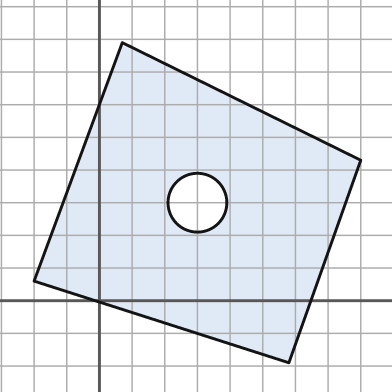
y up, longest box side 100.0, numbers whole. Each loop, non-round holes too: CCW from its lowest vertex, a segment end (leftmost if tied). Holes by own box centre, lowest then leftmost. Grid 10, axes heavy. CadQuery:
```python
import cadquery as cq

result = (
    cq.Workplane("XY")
    .moveTo(58.0, -19.0)
    .lineTo(80.0, 43.0)
    .lineTo(7.0, 79.0)
    .lineTo(-20.0, 6.0)
    .close()
    .moveTo(30.0, 30.0)
    .circle(9.0)
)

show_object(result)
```